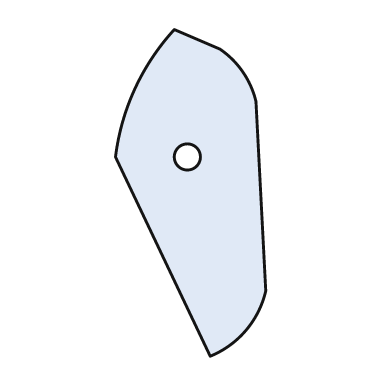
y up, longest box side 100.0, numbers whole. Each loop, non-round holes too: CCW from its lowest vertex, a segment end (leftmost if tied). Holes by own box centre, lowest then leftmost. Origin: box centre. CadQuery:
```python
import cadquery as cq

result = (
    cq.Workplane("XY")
    .moveTo(6.0, -50.0)
    .threePointArc((17.0, -42.0), (23.0, -30.0))
    .lineTo(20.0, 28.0)
    .threePointArc((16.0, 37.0), (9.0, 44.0))
    .lineTo(-5.0, 50.0)
    .threePointArc((-17.0, 32.0), (-23.0, 11.0))
    .close()
    .moveTo(-1.0, 11.0)
    .circle(4.0)
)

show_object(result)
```